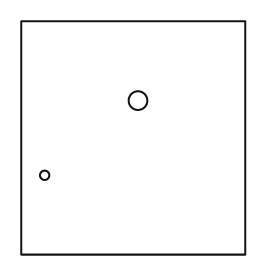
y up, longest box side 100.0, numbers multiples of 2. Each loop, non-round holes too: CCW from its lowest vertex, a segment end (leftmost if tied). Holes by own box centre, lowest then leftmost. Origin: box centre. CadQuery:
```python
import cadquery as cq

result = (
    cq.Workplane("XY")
    .moveTo(-48.0, -50.0)
    .lineTo(48.0, -50.0)
    .lineTo(48.0, 50.0)
    .lineTo(-48.0, 50.0)
    .close()
    .moveTo(-38.0, -16.0)
    .circle(2.0)
    .moveTo(2.0, 16.0)
    .circle(4.0)
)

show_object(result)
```